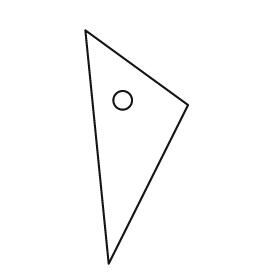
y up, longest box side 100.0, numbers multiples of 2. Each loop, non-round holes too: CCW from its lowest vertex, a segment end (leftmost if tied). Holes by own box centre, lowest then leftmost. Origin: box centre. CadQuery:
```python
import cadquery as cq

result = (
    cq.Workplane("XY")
    .moveTo(-12.0, -50.0)
    .lineTo(22.0, 18.0)
    .lineTo(-22.0, 50.0)
    .close()
    .moveTo(-6.0, 20.0)
    .circle(4.0)
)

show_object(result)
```